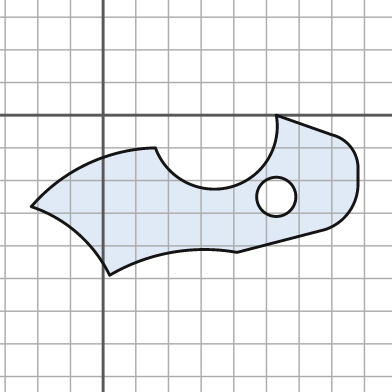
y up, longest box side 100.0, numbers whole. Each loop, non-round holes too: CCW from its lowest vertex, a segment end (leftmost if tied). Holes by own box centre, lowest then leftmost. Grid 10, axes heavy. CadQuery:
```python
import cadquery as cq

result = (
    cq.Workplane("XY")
    .moveTo(2.0, -49.0)
    .threePointArc((21.0, -42.0), (41.0, -42.0))
    .lineTo(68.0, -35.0)
    .threePointArc((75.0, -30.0), (78.0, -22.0))
    .lineTo(78.0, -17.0)
    .threePointArc((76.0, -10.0), (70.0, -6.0))
    .lineTo(53.0, 0.0)
    .threePointArc((39.0, -22.0), (16.0, -10.0))
    .threePointArc((-5.0, -15.0), (-22.0, -28.0))
    .threePointArc((-8.0, -36.0), (2.0, -49.0))
    .close()
    .moveTo(53.0, -25.0)
    .circle(6.0)
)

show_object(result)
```